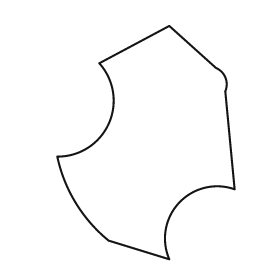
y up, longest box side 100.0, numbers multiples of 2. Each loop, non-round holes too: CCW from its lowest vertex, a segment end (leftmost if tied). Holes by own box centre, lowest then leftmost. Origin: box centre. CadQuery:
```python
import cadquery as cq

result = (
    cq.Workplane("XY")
    .moveTo(10.0, -50.0)
    .threePointArc((14.0, -26.0), (38.0, -20.0))
    .lineTo(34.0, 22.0)
    .threePointArc((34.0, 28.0), (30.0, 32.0))
    .lineTo(10.0, 50.0)
    .lineTo(-20.0, 34.0)
    .threePointArc((-16.0, 8.0), (-38.0, -6.0))
    .threePointArc((-30.0, -26.0), (-16.0, -42.0))
    .close()
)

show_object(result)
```